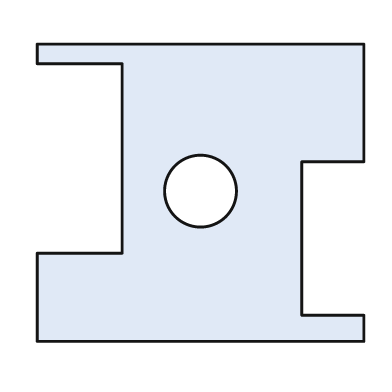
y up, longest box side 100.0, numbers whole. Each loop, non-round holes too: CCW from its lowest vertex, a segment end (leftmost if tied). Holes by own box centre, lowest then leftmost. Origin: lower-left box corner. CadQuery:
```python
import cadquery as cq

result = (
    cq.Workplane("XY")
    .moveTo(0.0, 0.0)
    .lineTo(100.0, 0.0)
    .lineTo(100.0, 8.0)
    .lineTo(81.0, 8.0)
    .lineTo(81.0, 55.0)
    .lineTo(100.0, 55.0)
    .lineTo(100.0, 91.0)
    .lineTo(0.0, 91.0)
    .lineTo(0.0, 85.0)
    .lineTo(26.0, 85.0)
    .lineTo(26.0, 27.0)
    .lineTo(0.0, 27.0)
    .close()
    .moveTo(50.0, 46.0)
    .circle(11.0)
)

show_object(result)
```